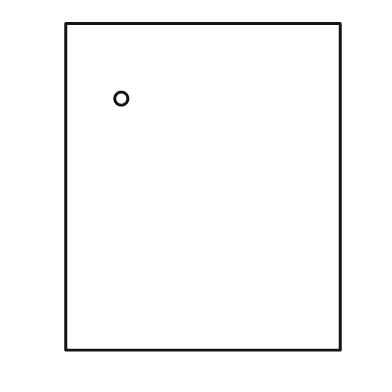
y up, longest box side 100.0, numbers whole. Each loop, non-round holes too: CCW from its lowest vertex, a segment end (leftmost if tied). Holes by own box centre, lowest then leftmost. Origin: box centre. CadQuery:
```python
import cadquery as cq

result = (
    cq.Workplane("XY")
    .moveTo(-42.0, -50.0)
    .lineTo(42.0, -50.0)
    .lineTo(42.0, 50.0)
    .lineTo(-42.0, 50.0)
    .close()
    .moveTo(-25.0, 27.0)
    .circle(2.0)
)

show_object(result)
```